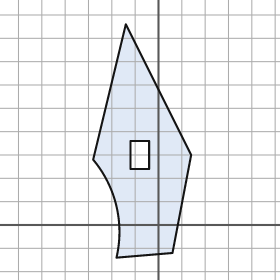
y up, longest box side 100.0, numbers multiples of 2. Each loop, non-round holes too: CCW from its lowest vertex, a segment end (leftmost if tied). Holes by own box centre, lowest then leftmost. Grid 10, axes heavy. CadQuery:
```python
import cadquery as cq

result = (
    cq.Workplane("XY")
    .moveTo(-18.0, -14.0)
    .lineTo(6.0, -12.0)
    .lineTo(14.0, 30.0)
    .lineTo(-14.0, 86.0)
    .lineTo(-28.0, 28.0)
    .threePointArc((-18.0, 8.0), (-18.0, -14.0))
    .close()
    .moveTo(-12.0, 24.0)
    .lineTo(-4.0, 24.0)
    .lineTo(-4.0, 36.0)
    .lineTo(-12.0, 36.0)
    .close()
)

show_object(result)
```